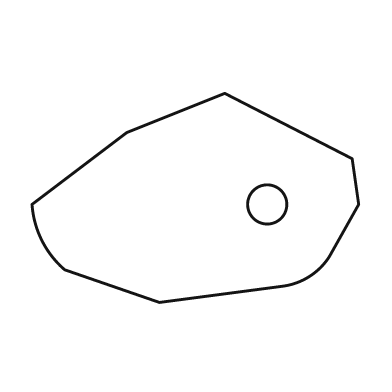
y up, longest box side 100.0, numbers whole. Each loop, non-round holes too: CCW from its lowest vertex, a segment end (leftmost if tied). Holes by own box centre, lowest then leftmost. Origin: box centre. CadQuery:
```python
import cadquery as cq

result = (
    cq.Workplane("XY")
    .moveTo(-11.0, -32.0)
    .lineTo(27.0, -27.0)
    .threePointArc((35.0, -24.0), (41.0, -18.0))
    .lineTo(50.0, -2.0)
    .lineTo(48.0, 12.0)
    .lineTo(9.0, 32.0)
    .lineTo(-21.0, 20.0)
    .lineTo(-50.0, -2.0)
    .threePointArc((-47.0, -13.0), (-40.0, -22.0))
    .close()
    .moveTo(22.0, -2.0)
    .circle(6.0)
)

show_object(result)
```